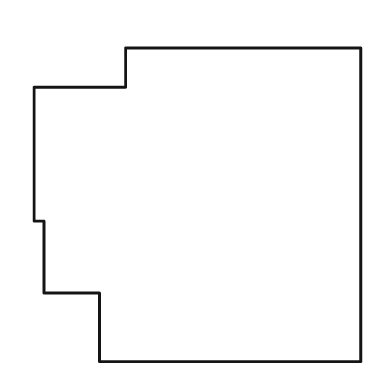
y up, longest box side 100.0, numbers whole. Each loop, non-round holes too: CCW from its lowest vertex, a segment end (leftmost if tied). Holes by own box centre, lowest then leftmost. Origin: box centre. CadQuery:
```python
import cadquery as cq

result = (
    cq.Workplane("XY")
    .moveTo(-30.0, -48.0)
    .lineTo(50.0, -48.0)
    .lineTo(50.0, 48.0)
    .lineTo(-22.0, 48.0)
    .lineTo(-22.0, 36.0)
    .lineTo(-50.0, 36.0)
    .lineTo(-50.0, -5.0)
    .lineTo(-47.0, -5.0)
    .lineTo(-47.0, -27.0)
    .lineTo(-30.0, -27.0)
    .close()
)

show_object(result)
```